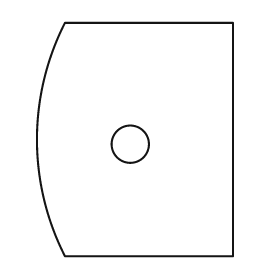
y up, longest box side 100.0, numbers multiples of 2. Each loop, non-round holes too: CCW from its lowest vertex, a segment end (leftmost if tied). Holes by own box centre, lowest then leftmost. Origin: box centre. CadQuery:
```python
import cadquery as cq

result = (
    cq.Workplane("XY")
    .moveTo(-30.0, -50.0)
    .lineTo(42.0, -50.0)
    .lineTo(42.0, 50.0)
    .lineTo(-30.0, 50.0)
    .threePointArc((-42.0, 0.0), (-30.0, -50.0))
    .close()
    .moveTo(-2.0, -2.0)
    .circle(8.0)
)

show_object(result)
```